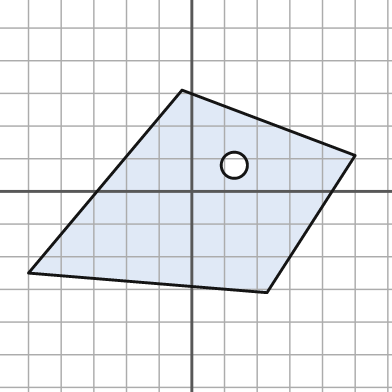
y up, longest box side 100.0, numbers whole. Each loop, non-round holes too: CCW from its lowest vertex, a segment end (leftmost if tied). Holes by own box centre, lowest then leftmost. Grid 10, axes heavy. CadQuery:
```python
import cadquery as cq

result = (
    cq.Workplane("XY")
    .moveTo(23.0, -31.0)
    .lineTo(50.0, 11.0)
    .lineTo(-3.0, 31.0)
    .lineTo(-50.0, -25.0)
    .close()
    .moveTo(13.0, 8.0)
    .circle(4.0)
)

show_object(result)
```